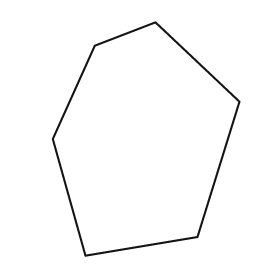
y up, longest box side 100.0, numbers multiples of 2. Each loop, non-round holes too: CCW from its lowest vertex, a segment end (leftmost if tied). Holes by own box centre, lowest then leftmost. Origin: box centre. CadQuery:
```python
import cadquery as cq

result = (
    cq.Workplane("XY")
    .moveTo(-26.0, -50.0)
    .lineTo(22.0, -42.0)
    .lineTo(40.0, 16.0)
    .lineTo(4.0, 50.0)
    .lineTo(-22.0, 40.0)
    .lineTo(-40.0, 0.0)
    .close()
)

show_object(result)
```